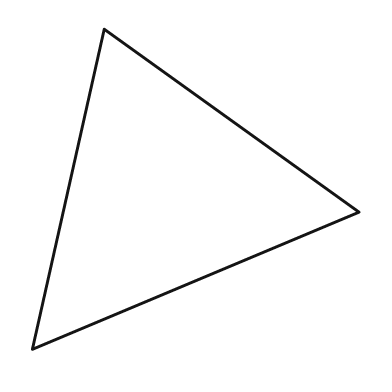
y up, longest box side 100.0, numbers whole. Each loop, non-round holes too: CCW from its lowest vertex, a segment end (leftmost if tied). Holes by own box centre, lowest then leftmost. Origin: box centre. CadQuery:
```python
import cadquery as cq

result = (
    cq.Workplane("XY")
    .moveTo(-50.0, -49.0)
    .lineTo(50.0, -7.0)
    .lineTo(-28.0, 49.0)
    .close()
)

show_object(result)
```